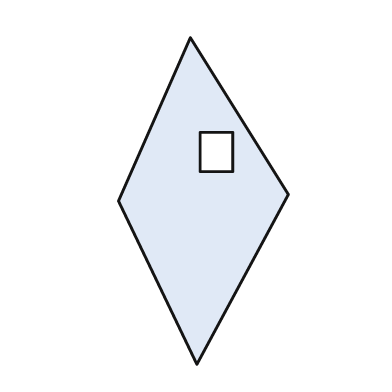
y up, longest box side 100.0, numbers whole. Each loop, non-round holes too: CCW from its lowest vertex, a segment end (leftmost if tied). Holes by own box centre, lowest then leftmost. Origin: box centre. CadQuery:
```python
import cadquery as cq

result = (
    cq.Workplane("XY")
    .moveTo(-2.0, -50.0)
    .lineTo(26.0, 2.0)
    .lineTo(-4.0, 50.0)
    .lineTo(-26.0, 0.0)
    .close()
    .moveTo(-1.0, 9.0)
    .lineTo(9.0, 9.0)
    .lineTo(9.0, 21.0)
    .lineTo(-1.0, 21.0)
    .close()
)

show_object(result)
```